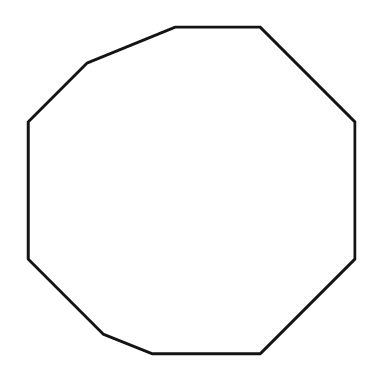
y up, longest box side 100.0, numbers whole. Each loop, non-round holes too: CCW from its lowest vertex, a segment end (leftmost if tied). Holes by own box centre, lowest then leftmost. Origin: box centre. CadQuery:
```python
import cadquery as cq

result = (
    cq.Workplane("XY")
    .moveTo(-12.0, -50.0)
    .lineTo(21.0, -50.0)
    .lineTo(50.0, -21.0)
    .lineTo(50.0, 21.0)
    .lineTo(21.0, 50.0)
    .lineTo(-5.0, 50.0)
    .lineTo(-32.0, 39.0)
    .lineTo(-50.0, 21.0)
    .lineTo(-50.0, -21.0)
    .lineTo(-27.0, -44.0)
    .close()
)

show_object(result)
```